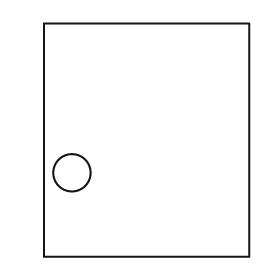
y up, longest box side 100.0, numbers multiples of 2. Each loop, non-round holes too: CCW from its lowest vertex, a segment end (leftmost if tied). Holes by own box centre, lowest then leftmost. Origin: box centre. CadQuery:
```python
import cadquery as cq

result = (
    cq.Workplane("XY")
    .moveTo(-44.0, -50.0)
    .lineTo(44.0, -50.0)
    .lineTo(44.0, 50.0)
    .lineTo(-44.0, 50.0)
    .close()
    .moveTo(-32.0, -14.0)
    .circle(8.0)
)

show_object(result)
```